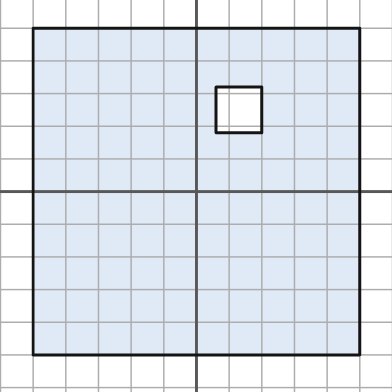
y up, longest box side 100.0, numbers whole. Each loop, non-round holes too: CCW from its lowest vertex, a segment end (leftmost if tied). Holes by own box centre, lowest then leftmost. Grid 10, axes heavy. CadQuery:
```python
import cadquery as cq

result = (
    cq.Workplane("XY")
    .moveTo(-50.0, -50.0)
    .lineTo(50.0, -50.0)
    .lineTo(50.0, 50.0)
    .lineTo(-50.0, 50.0)
    .close()
    .moveTo(6.0, 18.0)
    .lineTo(20.0, 18.0)
    .lineTo(20.0, 32.0)
    .lineTo(6.0, 32.0)
    .close()
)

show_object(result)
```